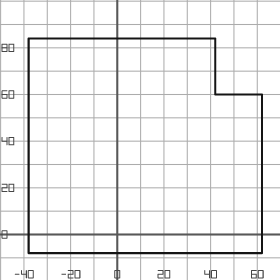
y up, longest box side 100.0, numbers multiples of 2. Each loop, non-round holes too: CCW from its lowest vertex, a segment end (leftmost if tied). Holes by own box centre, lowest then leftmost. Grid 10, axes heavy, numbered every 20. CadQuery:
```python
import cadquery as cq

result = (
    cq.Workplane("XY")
    .moveTo(-38.0, -8.0)
    .lineTo(62.0, -8.0)
    .lineTo(62.0, 60.0)
    .lineTo(42.0, 60.0)
    .lineTo(42.0, 84.0)
    .lineTo(-38.0, 84.0)
    .close()
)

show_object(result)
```